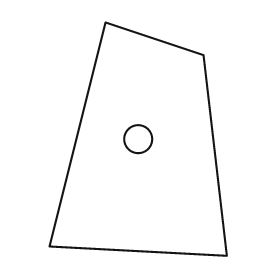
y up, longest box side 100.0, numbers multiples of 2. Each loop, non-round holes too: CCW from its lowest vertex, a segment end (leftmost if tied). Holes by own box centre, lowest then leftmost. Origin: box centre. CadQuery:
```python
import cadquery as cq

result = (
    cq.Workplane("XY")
    .moveTo(38.0, -50.0)
    .lineTo(28.0, 36.0)
    .lineTo(-14.0, 50.0)
    .lineTo(-38.0, -46.0)
    .close()
    .moveTo(0.0, 0.0)
    .circle(6.0)
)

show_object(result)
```